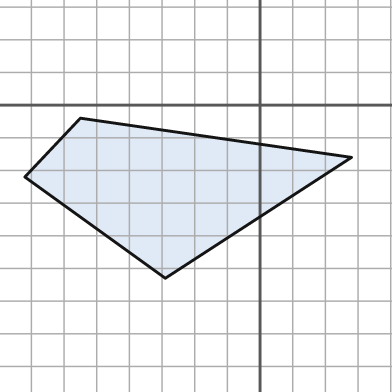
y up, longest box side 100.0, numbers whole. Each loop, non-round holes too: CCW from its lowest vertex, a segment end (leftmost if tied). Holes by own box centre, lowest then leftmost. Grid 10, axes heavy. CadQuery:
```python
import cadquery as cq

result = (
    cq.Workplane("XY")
    .moveTo(-29.0, -53.0)
    .lineTo(28.0, -16.0)
    .lineTo(-55.0, -4.0)
    .lineTo(-72.0, -22.0)
    .close()
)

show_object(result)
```